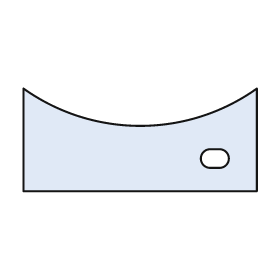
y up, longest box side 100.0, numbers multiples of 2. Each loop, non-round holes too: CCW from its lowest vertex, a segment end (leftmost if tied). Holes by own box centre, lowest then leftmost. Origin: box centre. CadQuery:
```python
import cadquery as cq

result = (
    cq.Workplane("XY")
    .moveTo(-50.0, -22.0)
    .lineTo(50.0, -22.0)
    .lineTo(50.0, 22.0)
    .threePointArc((0.0, 6.0), (-50.0, 22.0))
    .close()
    .moveTo(30.0, -12.0)
    .lineTo(34.0, -12.0)
    .threePointArc((38.0, -8.0), (34.0, -4.0))
    .lineTo(30.0, -4.0)
    .threePointArc((26.0, -8.0), (30.0, -12.0))
    .close()
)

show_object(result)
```